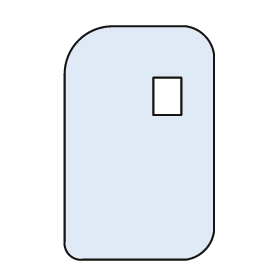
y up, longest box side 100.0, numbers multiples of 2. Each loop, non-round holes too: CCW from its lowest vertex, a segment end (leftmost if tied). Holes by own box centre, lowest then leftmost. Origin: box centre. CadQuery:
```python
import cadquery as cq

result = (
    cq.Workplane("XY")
    .moveTo(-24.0, -50.0)
    .lineTo(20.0, -50.0)
    .threePointArc((28.0, -46.0), (32.0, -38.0))
    .lineTo(32.0, 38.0)
    .threePointArc((28.0, 46.0), (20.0, 50.0))
    .lineTo(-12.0, 50.0)
    .threePointArc((-26.0, 44.0), (-32.0, 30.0))
    .lineTo(-32.0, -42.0)
    .threePointArc((-30.0, -48.0), (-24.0, -50.0))
    .close()
    .moveTo(6.0, 12.0)
    .lineTo(18.0, 12.0)
    .lineTo(18.0, 28.0)
    .lineTo(6.0, 28.0)
    .close()
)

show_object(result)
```